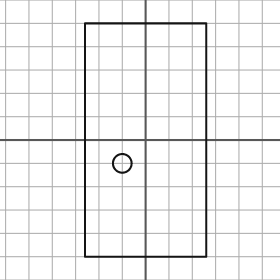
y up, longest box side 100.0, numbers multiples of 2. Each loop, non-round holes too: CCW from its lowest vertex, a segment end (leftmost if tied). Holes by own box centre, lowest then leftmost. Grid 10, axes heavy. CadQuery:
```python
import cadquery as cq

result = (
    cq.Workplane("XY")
    .moveTo(-26.0, -50.0)
    .lineTo(26.0, -50.0)
    .lineTo(26.0, 50.0)
    .lineTo(-26.0, 50.0)
    .close()
    .moveTo(-10.0, -10.0)
    .circle(4.0)
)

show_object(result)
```